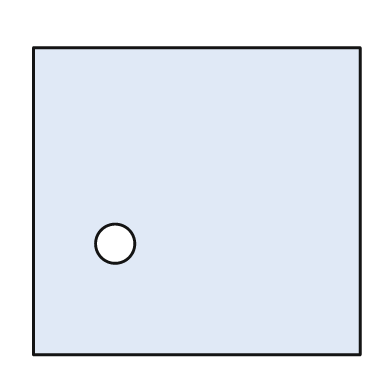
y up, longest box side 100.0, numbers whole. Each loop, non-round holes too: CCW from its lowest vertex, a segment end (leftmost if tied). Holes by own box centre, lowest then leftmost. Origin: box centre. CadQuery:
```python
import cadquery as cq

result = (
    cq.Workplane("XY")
    .moveTo(-50.0, -47.0)
    .lineTo(50.0, -47.0)
    .lineTo(50.0, 47.0)
    .lineTo(-50.0, 47.0)
    .close()
    .moveTo(-25.0, -13.0)
    .circle(6.0)
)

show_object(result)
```